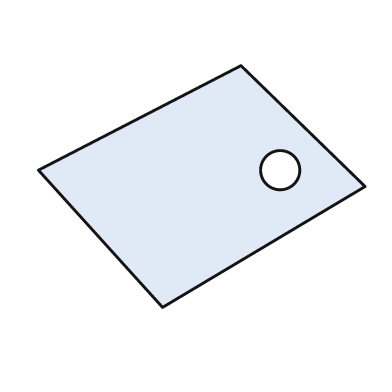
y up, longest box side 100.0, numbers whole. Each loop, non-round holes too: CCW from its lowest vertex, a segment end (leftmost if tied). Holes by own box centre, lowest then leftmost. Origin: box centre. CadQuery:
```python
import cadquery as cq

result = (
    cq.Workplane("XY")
    .moveTo(-12.0, -37.0)
    .lineTo(50.0, 0.0)
    .lineTo(12.0, 37.0)
    .lineTo(-50.0, 5.0)
    .close()
    .moveTo(24.0, 5.0)
    .circle(6.0)
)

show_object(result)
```